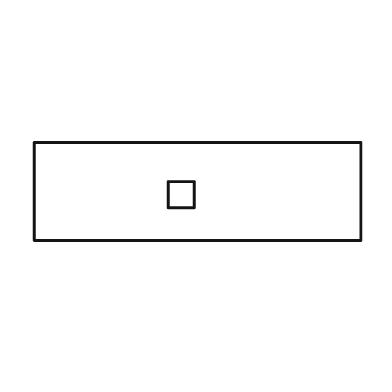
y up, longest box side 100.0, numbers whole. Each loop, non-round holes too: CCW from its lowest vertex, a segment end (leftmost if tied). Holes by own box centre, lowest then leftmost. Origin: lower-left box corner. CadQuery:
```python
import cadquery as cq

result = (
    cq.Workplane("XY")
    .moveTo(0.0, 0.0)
    .lineTo(100.0, 0.0)
    .lineTo(100.0, 30.0)
    .lineTo(0.0, 30.0)
    .close()
    .moveTo(41.0, 10.0)
    .lineTo(49.0, 10.0)
    .lineTo(49.0, 18.0)
    .lineTo(41.0, 18.0)
    .close()
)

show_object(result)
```